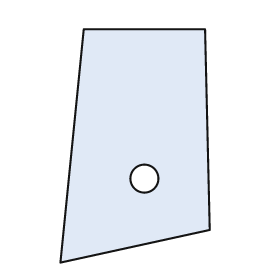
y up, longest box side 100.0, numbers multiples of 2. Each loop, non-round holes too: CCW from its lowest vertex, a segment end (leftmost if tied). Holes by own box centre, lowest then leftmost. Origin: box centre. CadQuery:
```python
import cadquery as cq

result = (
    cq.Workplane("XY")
    .moveTo(-32.0, -50.0)
    .lineTo(32.0, -36.0)
    .lineTo(30.0, 50.0)
    .lineTo(-22.0, 50.0)
    .close()
    .moveTo(4.0, -14.0)
    .circle(6.0)
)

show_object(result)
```